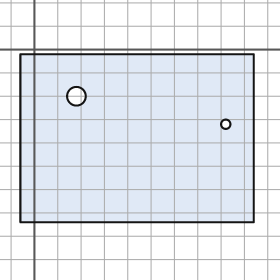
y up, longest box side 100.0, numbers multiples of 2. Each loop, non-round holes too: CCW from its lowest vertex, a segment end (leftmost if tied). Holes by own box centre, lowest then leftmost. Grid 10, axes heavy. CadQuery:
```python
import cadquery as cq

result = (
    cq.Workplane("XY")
    .moveTo(-6.0, -74.0)
    .lineTo(94.0, -74.0)
    .lineTo(94.0, -2.0)
    .lineTo(-6.0, -2.0)
    .close()
    .moveTo(82.0, -32.0)
    .circle(2.0)
    .moveTo(18.0, -20.0)
    .circle(4.0)
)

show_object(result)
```